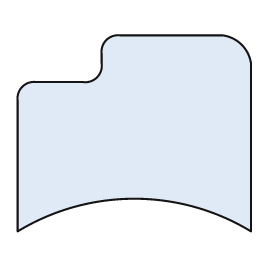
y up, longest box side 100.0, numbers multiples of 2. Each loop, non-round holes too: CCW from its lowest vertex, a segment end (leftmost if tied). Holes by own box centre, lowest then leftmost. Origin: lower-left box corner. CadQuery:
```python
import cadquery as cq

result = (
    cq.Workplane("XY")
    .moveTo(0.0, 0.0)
    .threePointArc((50.0, 14.0), (100.0, 0.0))
    .lineTo(100.0, 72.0)
    .threePointArc((96.0, 80.0), (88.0, 84.0))
    .lineTo(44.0, 84.0)
    .threePointArc((38.0, 82.0), (36.0, 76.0))
    .lineTo(36.0, 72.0)
    .threePointArc((34.0, 66.0), (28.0, 64.0))
    .lineTo(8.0, 64.0)
    .threePointArc((2.0, 62.0), (0.0, 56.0))
    .close()
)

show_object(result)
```